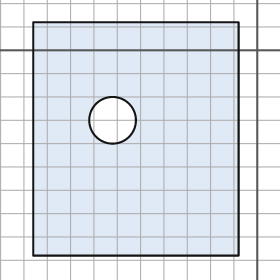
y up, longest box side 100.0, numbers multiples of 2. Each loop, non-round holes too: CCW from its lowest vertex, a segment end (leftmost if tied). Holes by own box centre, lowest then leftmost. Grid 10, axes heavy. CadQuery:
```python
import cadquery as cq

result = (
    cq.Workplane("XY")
    .moveTo(-96.0, -88.0)
    .lineTo(-8.0, -88.0)
    .lineTo(-8.0, 12.0)
    .lineTo(-96.0, 12.0)
    .close()
    .moveTo(-62.0, -30.0)
    .circle(10.0)
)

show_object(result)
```